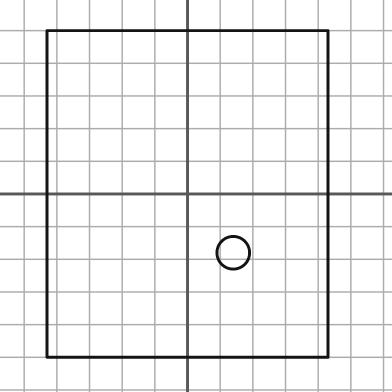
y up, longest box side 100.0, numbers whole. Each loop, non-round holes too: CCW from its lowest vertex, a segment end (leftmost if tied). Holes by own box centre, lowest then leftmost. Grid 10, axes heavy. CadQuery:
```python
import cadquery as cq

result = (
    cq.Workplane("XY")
    .moveTo(-43.0, -50.0)
    .lineTo(43.0, -50.0)
    .lineTo(43.0, 50.0)
    .lineTo(-43.0, 50.0)
    .close()
    .moveTo(14.0, -18.0)
    .circle(5.0)
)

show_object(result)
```